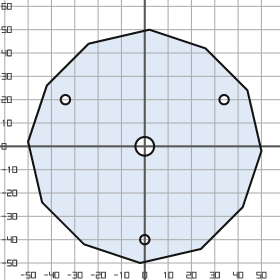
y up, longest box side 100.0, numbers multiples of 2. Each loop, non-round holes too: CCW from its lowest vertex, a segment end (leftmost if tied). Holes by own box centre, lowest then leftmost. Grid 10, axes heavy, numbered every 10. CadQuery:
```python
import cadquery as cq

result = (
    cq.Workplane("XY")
    .moveTo(-2.0, -50.0)
    .lineTo(24.0, -44.0)
    .lineTo(42.0, -26.0)
    .lineTo(50.0, -2.0)
    .lineTo(44.0, 24.0)
    .lineTo(26.0, 42.0)
    .lineTo(2.0, 50.0)
    .lineTo(-24.0, 44.0)
    .lineTo(-42.0, 26.0)
    .lineTo(-50.0, 2.0)
    .lineTo(-44.0, -24.0)
    .lineTo(-26.0, -42.0)
    .close()
    .moveTo(0.0, -40.0)
    .circle(2.0)
    .moveTo(0.0, 0.0)
    .circle(4.0)
    .moveTo(-34.0, 20.0)
    .circle(2.0)
    .moveTo(34.0, 20.0)
    .circle(2.0)
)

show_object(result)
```